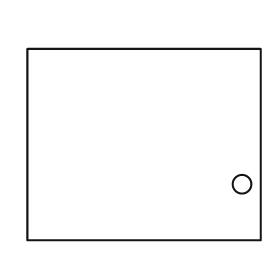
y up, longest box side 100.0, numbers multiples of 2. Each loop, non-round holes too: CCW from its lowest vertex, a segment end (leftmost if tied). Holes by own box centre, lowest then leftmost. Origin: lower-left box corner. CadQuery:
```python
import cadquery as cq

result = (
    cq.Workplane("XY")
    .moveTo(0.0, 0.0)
    .lineTo(100.0, 0.0)
    .lineTo(100.0, 82.0)
    .lineTo(0.0, 82.0)
    .close()
    .moveTo(92.0, 24.0)
    .circle(4.0)
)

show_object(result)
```